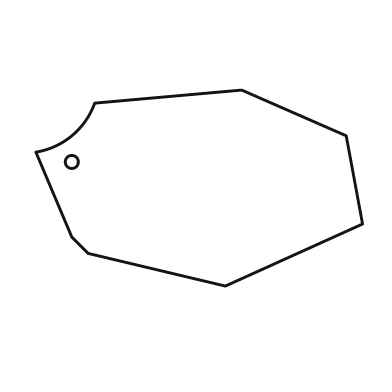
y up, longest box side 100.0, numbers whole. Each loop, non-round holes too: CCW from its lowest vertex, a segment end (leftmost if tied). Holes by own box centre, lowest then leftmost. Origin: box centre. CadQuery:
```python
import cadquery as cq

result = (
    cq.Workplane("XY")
    .moveTo(8.0, -30.0)
    .lineTo(50.0, -11.0)
    .lineTo(45.0, 16.0)
    .lineTo(13.0, 30.0)
    .lineTo(-32.0, 26.0)
    .threePointArc((-39.0, 16.0), (-50.0, 11.0))
    .lineTo(-39.0, -15.0)
    .lineTo(-34.0, -20.0)
    .close()
    .moveTo(-39.0, 8.0)
    .circle(2.0)
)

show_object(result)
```